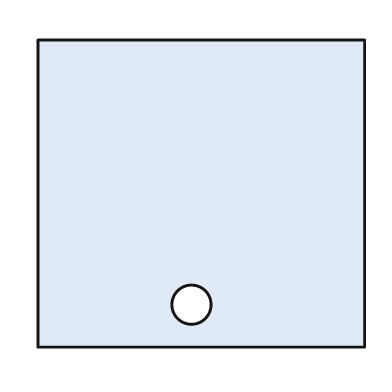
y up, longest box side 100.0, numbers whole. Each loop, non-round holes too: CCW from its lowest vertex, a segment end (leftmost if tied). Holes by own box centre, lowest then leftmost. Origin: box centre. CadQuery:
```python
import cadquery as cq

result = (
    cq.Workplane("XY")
    .moveTo(-50.0, -47.0)
    .lineTo(50.0, -47.0)
    .lineTo(50.0, 47.0)
    .lineTo(-50.0, 47.0)
    .close()
    .moveTo(-3.0, -34.0)
    .circle(6.0)
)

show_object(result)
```